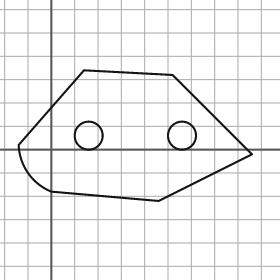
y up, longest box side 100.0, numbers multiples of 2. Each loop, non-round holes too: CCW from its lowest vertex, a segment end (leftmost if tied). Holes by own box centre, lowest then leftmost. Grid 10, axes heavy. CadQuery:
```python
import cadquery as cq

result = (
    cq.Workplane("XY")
    .moveTo(46.0, -22.0)
    .lineTo(86.0, -2.0)
    .lineTo(52.0, 32.0)
    .lineTo(14.0, 34.0)
    .lineTo(-14.0, 2.0)
    .threePointArc((-10.0, -10.0), (0.0, -18.0))
    .close()
    .moveTo(16.0, 6.0)
    .circle(6.0)
    .moveTo(56.0, 6.0)
    .circle(6.0)
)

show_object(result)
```